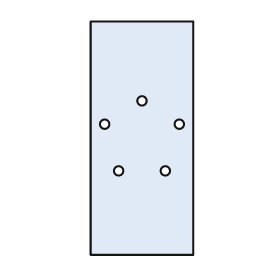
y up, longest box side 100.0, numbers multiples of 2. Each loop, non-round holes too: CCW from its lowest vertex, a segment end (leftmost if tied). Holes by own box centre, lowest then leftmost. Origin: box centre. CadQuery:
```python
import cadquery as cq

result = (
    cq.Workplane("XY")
    .moveTo(-22.0, -50.0)
    .lineTo(22.0, -50.0)
    .lineTo(22.0, 50.0)
    .lineTo(-22.0, 50.0)
    .close()
    .moveTo(-10.0, -14.0)
    .circle(2.0)
    .moveTo(10.0, -14.0)
    .circle(2.0)
    .moveTo(-16.0, 6.0)
    .circle(2.0)
    .moveTo(16.0, 6.0)
    .circle(2.0)
    .moveTo(0.0, 16.0)
    .circle(2.0)
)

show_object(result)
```